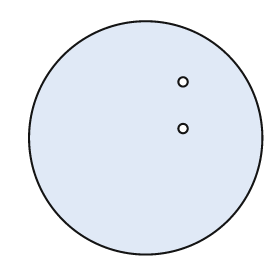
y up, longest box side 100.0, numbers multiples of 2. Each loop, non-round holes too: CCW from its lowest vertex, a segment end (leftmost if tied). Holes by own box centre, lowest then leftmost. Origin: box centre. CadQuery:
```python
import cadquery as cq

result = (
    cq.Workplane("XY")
    .moveTo(0.0, 0.0)
    .circle(50.0)
    .moveTo(16.0, 4.0)
    .circle(2.0)
    .moveTo(16.0, 24.0)
    .circle(2.0)
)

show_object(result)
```